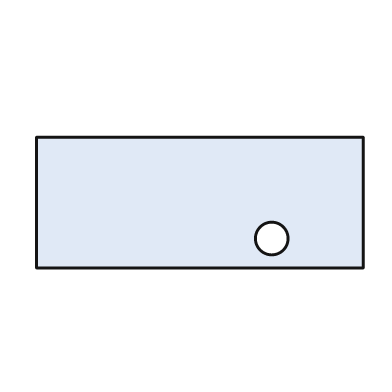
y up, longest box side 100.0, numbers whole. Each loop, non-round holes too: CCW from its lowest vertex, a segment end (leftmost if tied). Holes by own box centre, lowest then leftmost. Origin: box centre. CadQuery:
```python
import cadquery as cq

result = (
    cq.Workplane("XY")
    .moveTo(-50.0, -20.0)
    .lineTo(50.0, -20.0)
    .lineTo(50.0, 20.0)
    .lineTo(-50.0, 20.0)
    .close()
    .moveTo(22.0, -11.0)
    .circle(5.0)
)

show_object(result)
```